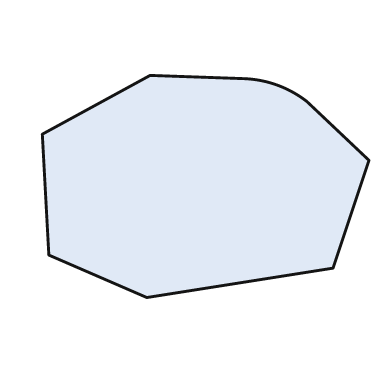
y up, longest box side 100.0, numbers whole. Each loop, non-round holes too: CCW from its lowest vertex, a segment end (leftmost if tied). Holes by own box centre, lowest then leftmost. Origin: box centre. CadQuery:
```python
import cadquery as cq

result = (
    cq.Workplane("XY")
    .moveTo(-18.0, -34.0)
    .lineTo(39.0, -25.0)
    .lineTo(50.0, 8.0)
    .lineTo(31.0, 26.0)
    .threePointArc((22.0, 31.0), (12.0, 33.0))
    .lineTo(-17.0, 34.0)
    .lineTo(-50.0, 16.0)
    .lineTo(-48.0, -21.0)
    .close()
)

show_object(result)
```